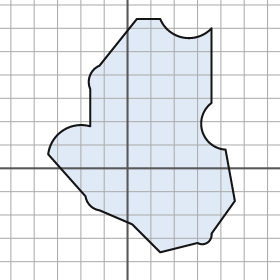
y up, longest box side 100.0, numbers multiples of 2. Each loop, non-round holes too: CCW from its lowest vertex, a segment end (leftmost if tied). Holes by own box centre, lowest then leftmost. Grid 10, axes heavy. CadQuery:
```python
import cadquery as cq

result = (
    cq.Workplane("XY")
    .moveTo(14.0, -36.0)
    .lineTo(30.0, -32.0)
    .threePointArc((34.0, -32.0), (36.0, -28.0))
    .lineTo(46.0, -14.0)
    .lineTo(42.0, 8.0)
    .threePointArc((32.0, 16.0), (36.0, 28.0))
    .lineTo(36.0, 60.0)
    .threePointArc((24.0, 56.0), (14.0, 64.0))
    .lineTo(4.0, 64.0)
    .lineTo(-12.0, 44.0)
    .threePointArc((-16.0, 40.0), (-16.0, 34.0))
    .lineTo(-16.0, 18.0)
    .threePointArc((-28.0, 16.0), (-34.0, 6.0))
    .lineTo(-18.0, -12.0)
    .threePointArc((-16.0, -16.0), (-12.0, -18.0))
    .lineTo(2.0, -24.0)
    .close()
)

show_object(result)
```